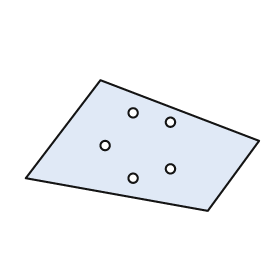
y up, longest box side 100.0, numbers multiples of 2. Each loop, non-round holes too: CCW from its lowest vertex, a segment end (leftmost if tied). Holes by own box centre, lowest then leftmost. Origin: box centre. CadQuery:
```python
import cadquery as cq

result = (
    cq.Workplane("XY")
    .moveTo(28.0, -28.0)
    .lineTo(50.0, 2.0)
    .lineTo(-18.0, 28.0)
    .lineTo(-50.0, -14.0)
    .close()
    .moveTo(-4.0, -14.0)
    .circle(2.0)
    .moveTo(12.0, -10.0)
    .circle(2.0)
    .moveTo(-16.0, 0.0)
    .circle(2.0)
    .moveTo(12.0, 10.0)
    .circle(2.0)
    .moveTo(-4.0, 14.0)
    .circle(2.0)
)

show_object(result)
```